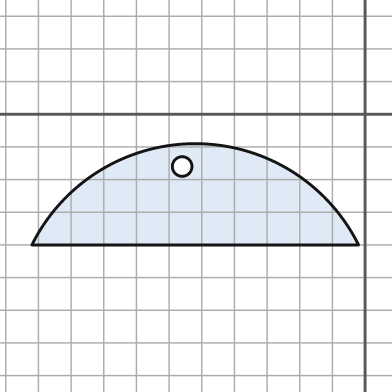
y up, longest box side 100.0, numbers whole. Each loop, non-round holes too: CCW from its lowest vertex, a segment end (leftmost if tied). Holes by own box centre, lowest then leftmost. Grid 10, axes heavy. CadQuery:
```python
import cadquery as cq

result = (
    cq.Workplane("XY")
    .moveTo(-102.0, -40.0)
    .lineTo(-2.0, -40.0)
    .threePointArc((-52.0, -9.0), (-102.0, -40.0))
    .close()
    .moveTo(-56.0, -16.0)
    .circle(3.0)
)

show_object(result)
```